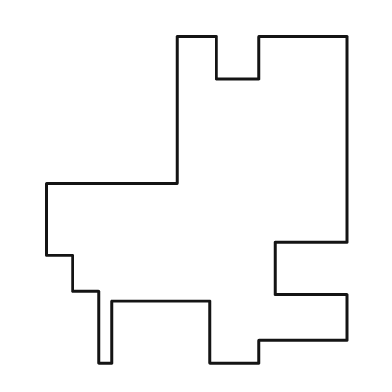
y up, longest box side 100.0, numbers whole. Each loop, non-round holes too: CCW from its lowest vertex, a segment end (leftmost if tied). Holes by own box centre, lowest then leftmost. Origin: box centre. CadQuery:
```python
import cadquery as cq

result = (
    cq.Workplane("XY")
    .moveTo(-30.0, -50.0)
    .lineTo(-26.0, -50.0)
    .lineTo(-26.0, -31.0)
    .lineTo(4.0, -31.0)
    .lineTo(4.0, -50.0)
    .lineTo(19.0, -50.0)
    .lineTo(19.0, -43.0)
    .lineTo(46.0, -43.0)
    .lineTo(46.0, -29.0)
    .lineTo(24.0, -29.0)
    .lineTo(24.0, -13.0)
    .lineTo(46.0, -13.0)
    .lineTo(46.0, 50.0)
    .lineTo(19.0, 50.0)
    .lineTo(19.0, 37.0)
    .lineTo(6.0, 37.0)
    .lineTo(6.0, 50.0)
    .lineTo(-6.0, 50.0)
    .lineTo(-6.0, 5.0)
    .lineTo(-46.0, 5.0)
    .lineTo(-46.0, -17.0)
    .lineTo(-38.0, -17.0)
    .lineTo(-38.0, -28.0)
    .lineTo(-30.0, -28.0)
    .close()
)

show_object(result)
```